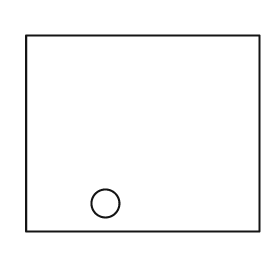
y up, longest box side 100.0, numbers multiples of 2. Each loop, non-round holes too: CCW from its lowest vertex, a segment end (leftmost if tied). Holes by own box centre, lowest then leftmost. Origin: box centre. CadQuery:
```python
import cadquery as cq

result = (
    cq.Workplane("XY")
    .moveTo(-50.0, -42.0)
    .lineTo(50.0, -42.0)
    .lineTo(50.0, 42.0)
    .lineTo(-50.0, 42.0)
    .close()
    .moveTo(-16.0, -30.0)
    .circle(6.0)
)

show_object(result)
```